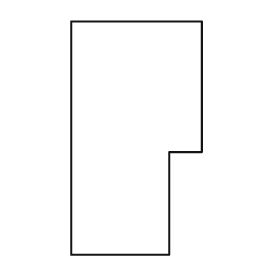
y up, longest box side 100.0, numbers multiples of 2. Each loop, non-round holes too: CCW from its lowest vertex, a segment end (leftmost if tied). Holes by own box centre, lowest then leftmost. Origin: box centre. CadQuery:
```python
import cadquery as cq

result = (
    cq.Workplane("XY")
    .moveTo(-28.0, -50.0)
    .lineTo(14.0, -50.0)
    .lineTo(14.0, -6.0)
    .lineTo(28.0, -6.0)
    .lineTo(28.0, 50.0)
    .lineTo(-28.0, 50.0)
    .close()
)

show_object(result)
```